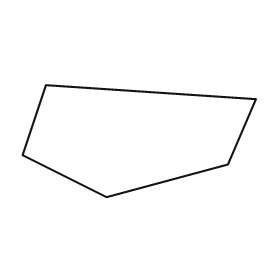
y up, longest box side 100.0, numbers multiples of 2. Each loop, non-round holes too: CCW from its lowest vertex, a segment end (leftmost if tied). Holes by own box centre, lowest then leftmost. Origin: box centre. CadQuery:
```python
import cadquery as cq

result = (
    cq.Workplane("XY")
    .moveTo(-14.0, -24.0)
    .lineTo(38.0, -10.0)
    .lineTo(50.0, 18.0)
    .lineTo(-40.0, 24.0)
    .lineTo(-50.0, -6.0)
    .close()
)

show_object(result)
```